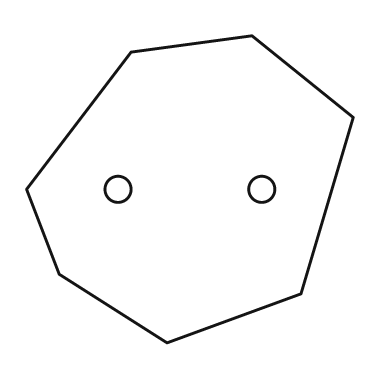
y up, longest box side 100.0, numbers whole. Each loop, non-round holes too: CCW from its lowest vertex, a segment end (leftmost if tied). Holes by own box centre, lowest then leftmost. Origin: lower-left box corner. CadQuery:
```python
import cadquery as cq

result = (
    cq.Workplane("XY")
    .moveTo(43.0, 0.0)
    .lineTo(84.0, 15.0)
    .lineTo(100.0, 69.0)
    .lineTo(69.0, 94.0)
    .lineTo(32.0, 89.0)
    .lineTo(0.0, 47.0)
    .lineTo(10.0, 21.0)
    .close()
    .moveTo(28.0, 47.0)
    .circle(4.0)
    .moveTo(72.0, 47.0)
    .circle(4.0)
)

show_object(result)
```